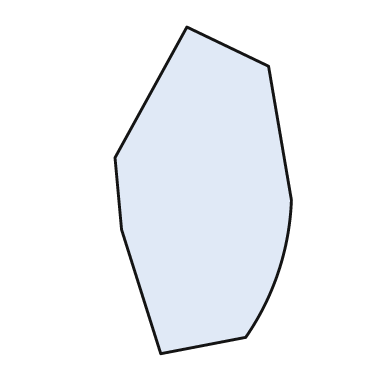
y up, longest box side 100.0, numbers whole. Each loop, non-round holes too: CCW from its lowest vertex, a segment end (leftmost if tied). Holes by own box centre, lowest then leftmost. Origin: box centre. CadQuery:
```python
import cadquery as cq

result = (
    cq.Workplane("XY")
    .moveTo(-13.0, -50.0)
    .lineTo(13.0, -45.0)
    .threePointArc((23.0, -25.0), (27.0, -3.0))
    .lineTo(20.0, 38.0)
    .lineTo(-5.0, 50.0)
    .lineTo(-27.0, 10.0)
    .lineTo(-25.0, -12.0)
    .close()
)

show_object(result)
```